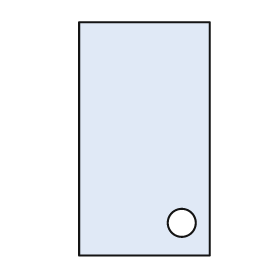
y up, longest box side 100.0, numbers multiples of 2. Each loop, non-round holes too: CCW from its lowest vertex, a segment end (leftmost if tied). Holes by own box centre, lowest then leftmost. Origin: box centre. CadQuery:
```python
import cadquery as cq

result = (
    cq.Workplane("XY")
    .moveTo(-28.0, -50.0)
    .lineTo(28.0, -50.0)
    .lineTo(28.0, 50.0)
    .lineTo(-28.0, 50.0)
    .close()
    .moveTo(16.0, -36.0)
    .circle(6.0)
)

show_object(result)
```